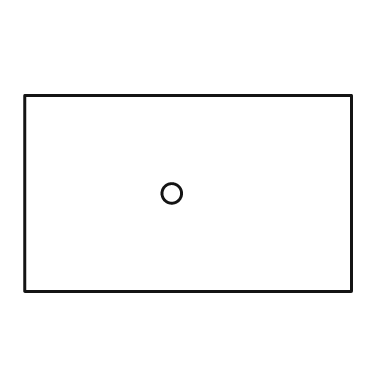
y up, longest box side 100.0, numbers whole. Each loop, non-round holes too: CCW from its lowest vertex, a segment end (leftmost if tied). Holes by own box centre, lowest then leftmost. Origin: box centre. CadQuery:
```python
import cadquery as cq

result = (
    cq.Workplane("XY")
    .moveTo(-50.0, -30.0)
    .lineTo(50.0, -30.0)
    .lineTo(50.0, 30.0)
    .lineTo(-50.0, 30.0)
    .close()
    .moveTo(-5.0, 0.0)
    .circle(3.0)
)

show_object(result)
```